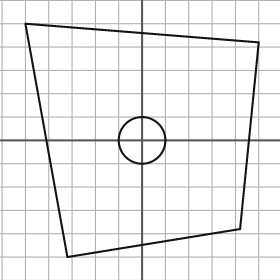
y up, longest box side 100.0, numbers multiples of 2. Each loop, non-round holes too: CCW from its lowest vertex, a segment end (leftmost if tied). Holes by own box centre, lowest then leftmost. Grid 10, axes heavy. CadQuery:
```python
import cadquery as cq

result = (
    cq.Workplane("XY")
    .moveTo(-32.0, -50.0)
    .lineTo(42.0, -38.0)
    .lineTo(50.0, 42.0)
    .lineTo(-50.0, 50.0)
    .close()
    .moveTo(0.0, 0.0)
    .circle(10.0)
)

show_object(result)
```